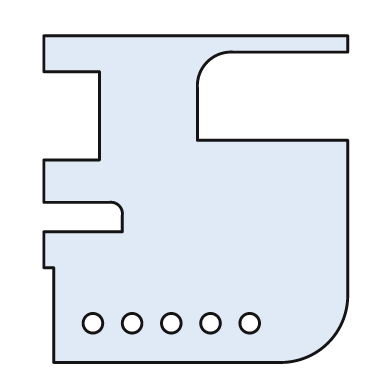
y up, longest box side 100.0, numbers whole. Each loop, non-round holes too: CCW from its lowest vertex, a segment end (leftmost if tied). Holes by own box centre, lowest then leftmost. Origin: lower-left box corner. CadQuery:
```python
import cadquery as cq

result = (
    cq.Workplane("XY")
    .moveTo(3.0, 0.0)
    .lineTo(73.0, 0.0)
    .threePointArc((87.0, 6.0), (93.0, 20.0))
    .lineTo(93.0, 68.0)
    .lineTo(47.0, 68.0)
    .lineTo(47.0, 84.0)
    .threePointArc((50.0, 92.0), (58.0, 95.0))
    .lineTo(93.0, 95.0)
    .lineTo(93.0, 100.0)
    .lineTo(0.0, 100.0)
    .lineTo(0.0, 89.0)
    .lineTo(17.0, 89.0)
    .lineTo(17.0, 62.0)
    .lineTo(0.0, 62.0)
    .lineTo(0.0, 49.0)
    .lineTo(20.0, 49.0)
    .threePointArc((23.0, 48.0), (24.0, 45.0))
    .lineTo(24.0, 40.0)
    .lineTo(0.0, 40.0)
    .lineTo(0.0, 29.0)
    .lineTo(3.0, 29.0)
    .close()
    .moveTo(15.0, 12.0)
    .circle(3.0)
    .moveTo(27.0, 12.0)
    .circle(3.0)
    .moveTo(39.0, 12.0)
    .circle(3.0)
    .moveTo(51.0, 12.0)
    .circle(3.0)
    .moveTo(63.0, 12.0)
    .circle(3.0)
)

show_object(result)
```